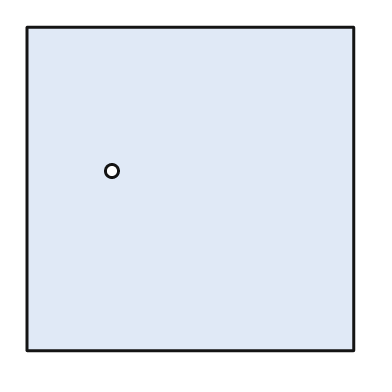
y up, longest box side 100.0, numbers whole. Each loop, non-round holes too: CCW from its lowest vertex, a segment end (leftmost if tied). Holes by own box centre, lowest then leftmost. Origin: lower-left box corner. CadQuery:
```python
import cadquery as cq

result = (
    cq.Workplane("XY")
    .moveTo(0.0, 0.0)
    .lineTo(100.0, 0.0)
    .lineTo(100.0, 99.0)
    .lineTo(0.0, 99.0)
    .close()
    .moveTo(26.0, 55.0)
    .circle(2.0)
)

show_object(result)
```